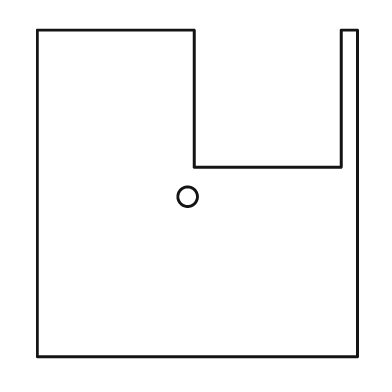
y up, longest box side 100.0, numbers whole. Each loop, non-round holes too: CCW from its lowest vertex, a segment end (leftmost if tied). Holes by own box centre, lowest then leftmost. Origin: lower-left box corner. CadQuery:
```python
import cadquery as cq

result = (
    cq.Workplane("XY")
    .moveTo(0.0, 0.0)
    .lineTo(98.0, 0.0)
    .lineTo(98.0, 100.0)
    .lineTo(93.0, 100.0)
    .lineTo(93.0, 58.0)
    .lineTo(48.0, 58.0)
    .lineTo(48.0, 100.0)
    .lineTo(0.0, 100.0)
    .close()
    .moveTo(46.0, 49.0)
    .circle(3.0)
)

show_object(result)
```